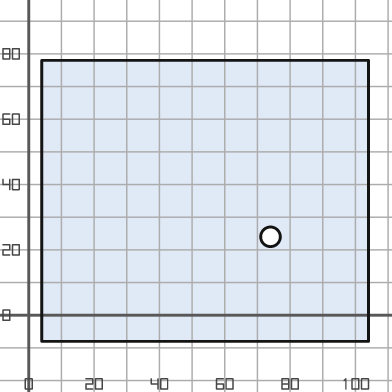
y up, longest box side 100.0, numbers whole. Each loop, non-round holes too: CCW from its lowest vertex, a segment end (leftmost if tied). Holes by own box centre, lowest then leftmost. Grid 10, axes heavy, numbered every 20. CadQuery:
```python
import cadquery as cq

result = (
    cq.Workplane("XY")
    .moveTo(4.0, -8.0)
    .lineTo(104.0, -8.0)
    .lineTo(104.0, 78.0)
    .lineTo(4.0, 78.0)
    .close()
    .moveTo(74.0, 24.0)
    .circle(3.0)
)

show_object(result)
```